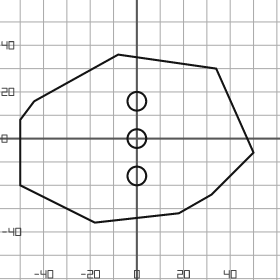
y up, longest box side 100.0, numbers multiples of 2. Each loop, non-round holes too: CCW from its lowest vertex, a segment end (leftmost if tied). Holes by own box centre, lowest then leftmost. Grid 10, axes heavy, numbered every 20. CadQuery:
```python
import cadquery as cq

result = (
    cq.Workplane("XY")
    .moveTo(-18.0, -36.0)
    .lineTo(18.0, -32.0)
    .lineTo(32.0, -24.0)
    .lineTo(50.0, -6.0)
    .lineTo(34.0, 30.0)
    .lineTo(-8.0, 36.0)
    .lineTo(-44.0, 16.0)
    .lineTo(-50.0, 8.0)
    .lineTo(-50.0, -20.0)
    .close()
    .moveTo(0.0, -16.0)
    .circle(4.0)
    .moveTo(0.0, 0.0)
    .circle(4.0)
    .moveTo(0.0, 16.0)
    .circle(4.0)
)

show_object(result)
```